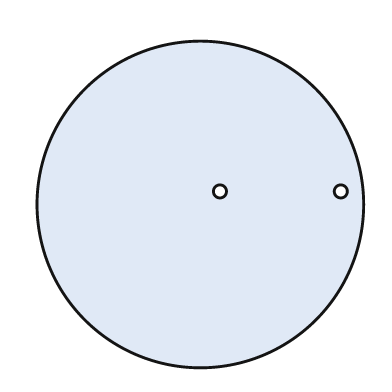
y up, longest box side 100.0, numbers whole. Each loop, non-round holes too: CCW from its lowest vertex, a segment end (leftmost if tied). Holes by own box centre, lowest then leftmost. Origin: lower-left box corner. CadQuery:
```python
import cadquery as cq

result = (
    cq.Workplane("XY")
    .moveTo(50.0, 50.0)
    .circle(50.0)
    .moveTo(56.0, 54.0)
    .circle(2.0)
    .moveTo(93.0, 54.0)
    .circle(2.0)
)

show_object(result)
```